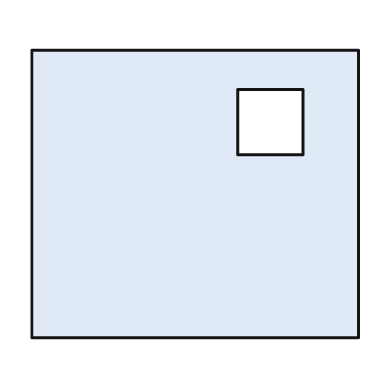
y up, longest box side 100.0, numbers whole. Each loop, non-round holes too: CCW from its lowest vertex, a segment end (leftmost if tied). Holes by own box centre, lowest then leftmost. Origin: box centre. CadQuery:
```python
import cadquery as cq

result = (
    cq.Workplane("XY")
    .moveTo(-50.0, -44.0)
    .lineTo(50.0, -44.0)
    .lineTo(50.0, 44.0)
    .lineTo(-50.0, 44.0)
    .close()
    .moveTo(13.0, 12.0)
    .lineTo(33.0, 12.0)
    .lineTo(33.0, 32.0)
    .lineTo(13.0, 32.0)
    .close()
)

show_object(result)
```